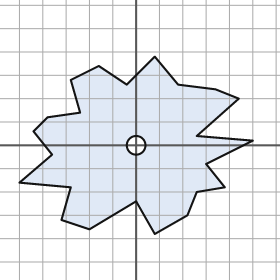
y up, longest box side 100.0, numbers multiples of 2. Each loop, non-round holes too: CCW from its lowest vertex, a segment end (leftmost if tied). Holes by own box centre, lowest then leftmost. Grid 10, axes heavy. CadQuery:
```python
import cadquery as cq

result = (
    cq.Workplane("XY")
    .moveTo(8.0, -38.0)
    .lineTo(22.0, -30.0)
    .lineTo(26.0, -20.0)
    .lineTo(38.0, -18.0)
    .lineTo(30.0, -8.0)
    .lineTo(50.0, 2.0)
    .lineTo(26.0, 4.0)
    .lineTo(44.0, 20.0)
    .lineTo(34.0, 24.0)
    .lineTo(18.0, 26.0)
    .lineTo(8.0, 38.0)
    .lineTo(-4.0, 26.0)
    .lineTo(-16.0, 34.0)
    .lineTo(-28.0, 28.0)
    .lineTo(-24.0, 14.0)
    .lineTo(-38.0, 12.0)
    .lineTo(-44.0, 6.0)
    .lineTo(-36.0, -4.0)
    .lineTo(-50.0, -16.0)
    .lineTo(-28.0, -18.0)
    .lineTo(-32.0, -32.0)
    .lineTo(-20.0, -36.0)
    .lineTo(0.0, -24.0)
    .close()
    .moveTo(0.0, 0.0)
    .circle(4.0)
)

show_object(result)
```